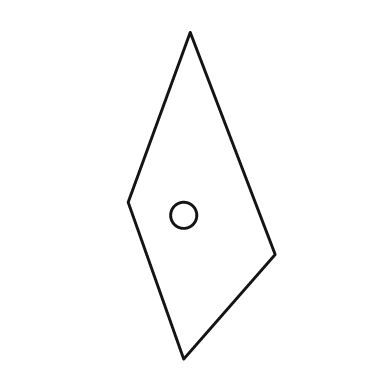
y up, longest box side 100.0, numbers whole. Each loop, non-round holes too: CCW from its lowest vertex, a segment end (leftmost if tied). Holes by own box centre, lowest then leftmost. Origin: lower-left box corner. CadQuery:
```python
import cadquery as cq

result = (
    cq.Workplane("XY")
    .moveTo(17.0, 0.0)
    .lineTo(45.0, 32.0)
    .lineTo(19.0, 100.0)
    .lineTo(0.0, 48.0)
    .close()
    .moveTo(17.0, 44.0)
    .circle(4.0)
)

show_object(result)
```